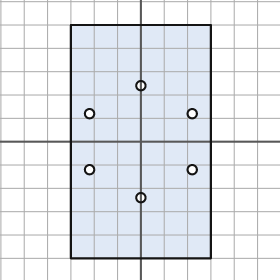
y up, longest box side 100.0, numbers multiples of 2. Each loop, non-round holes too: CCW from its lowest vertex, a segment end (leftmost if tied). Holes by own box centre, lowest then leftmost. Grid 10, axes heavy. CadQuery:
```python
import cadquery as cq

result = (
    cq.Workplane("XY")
    .moveTo(-30.0, -50.0)
    .lineTo(30.0, -50.0)
    .lineTo(30.0, 50.0)
    .lineTo(-30.0, 50.0)
    .close()
    .moveTo(0.0, -24.0)
    .circle(2.0)
    .moveTo(-22.0, -12.0)
    .circle(2.0)
    .moveTo(22.0, -12.0)
    .circle(2.0)
    .moveTo(-22.0, 12.0)
    .circle(2.0)
    .moveTo(22.0, 12.0)
    .circle(2.0)
    .moveTo(0.0, 24.0)
    .circle(2.0)
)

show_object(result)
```